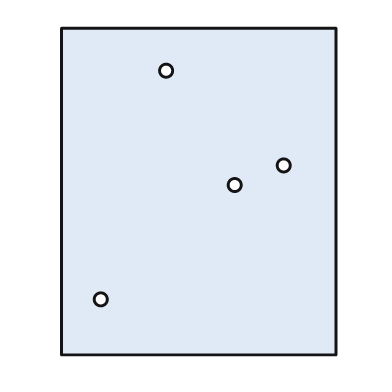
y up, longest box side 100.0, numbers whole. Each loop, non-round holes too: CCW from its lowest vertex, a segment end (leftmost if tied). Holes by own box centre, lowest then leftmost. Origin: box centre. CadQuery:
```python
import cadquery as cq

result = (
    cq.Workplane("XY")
    .moveTo(-42.0, -50.0)
    .lineTo(42.0, -50.0)
    .lineTo(42.0, 50.0)
    .lineTo(-42.0, 50.0)
    .close()
    .moveTo(-30.0, -33.0)
    .circle(2.0)
    .moveTo(11.0, 2.0)
    .circle(2.0)
    .moveTo(26.0, 8.0)
    .circle(2.0)
    .moveTo(-10.0, 37.0)
    .circle(2.0)
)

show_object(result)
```